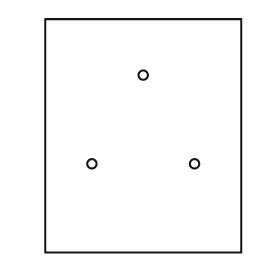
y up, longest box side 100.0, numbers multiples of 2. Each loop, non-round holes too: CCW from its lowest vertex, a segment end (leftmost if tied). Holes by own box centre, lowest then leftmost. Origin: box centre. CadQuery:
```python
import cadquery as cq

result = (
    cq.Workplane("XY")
    .moveTo(-42.0, -50.0)
    .lineTo(42.0, -50.0)
    .lineTo(42.0, 50.0)
    .lineTo(-42.0, 50.0)
    .close()
    .moveTo(-22.0, -12.0)
    .circle(2.0)
    .moveTo(22.0, -12.0)
    .circle(2.0)
    .moveTo(0.0, 26.0)
    .circle(2.0)
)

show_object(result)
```